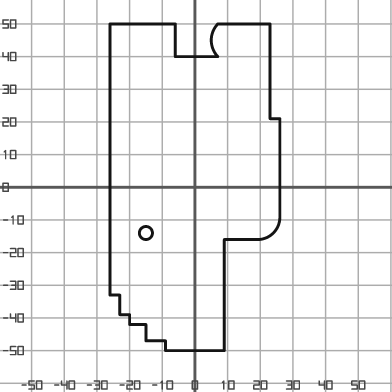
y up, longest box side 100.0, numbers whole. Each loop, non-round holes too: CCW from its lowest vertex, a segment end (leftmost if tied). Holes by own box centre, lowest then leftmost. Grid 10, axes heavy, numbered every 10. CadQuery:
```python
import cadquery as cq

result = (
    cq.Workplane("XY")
    .moveTo(-9.0, -50.0)
    .lineTo(9.0, -50.0)
    .lineTo(9.0, -16.0)
    .lineTo(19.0, -16.0)
    .threePointArc((24.0, -14.0), (26.0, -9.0))
    .lineTo(26.0, 21.0)
    .lineTo(23.0, 21.0)
    .lineTo(23.0, 50.0)
    .lineTo(7.0, 50.0)
    .threePointArc((5.0, 45.0), (7.0, 40.0))
    .lineTo(-6.0, 40.0)
    .lineTo(-6.0, 50.0)
    .lineTo(-26.0, 50.0)
    .lineTo(-26.0, -33.0)
    .lineTo(-23.0, -33.0)
    .lineTo(-23.0, -39.0)
    .lineTo(-20.0, -39.0)
    .lineTo(-20.0, -42.0)
    .lineTo(-15.0, -42.0)
    .lineTo(-15.0, -47.0)
    .lineTo(-9.0, -47.0)
    .close()
    .moveTo(-15.0, -14.0)
    .circle(2.0)
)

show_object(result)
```